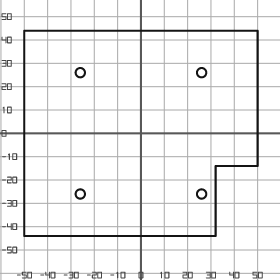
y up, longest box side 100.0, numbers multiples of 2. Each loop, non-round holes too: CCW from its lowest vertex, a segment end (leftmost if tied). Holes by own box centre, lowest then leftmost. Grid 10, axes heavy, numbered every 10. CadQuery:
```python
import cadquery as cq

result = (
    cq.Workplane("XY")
    .moveTo(-50.0, -44.0)
    .lineTo(32.0, -44.0)
    .lineTo(32.0, -14.0)
    .lineTo(50.0, -14.0)
    .lineTo(50.0, 44.0)
    .lineTo(-50.0, 44.0)
    .close()
    .moveTo(-26.0, -26.0)
    .circle(2.0)
    .moveTo(26.0, -26.0)
    .circle(2.0)
    .moveTo(-26.0, 26.0)
    .circle(2.0)
    .moveTo(26.0, 26.0)
    .circle(2.0)
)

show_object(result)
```